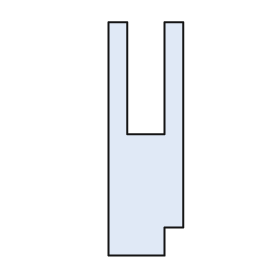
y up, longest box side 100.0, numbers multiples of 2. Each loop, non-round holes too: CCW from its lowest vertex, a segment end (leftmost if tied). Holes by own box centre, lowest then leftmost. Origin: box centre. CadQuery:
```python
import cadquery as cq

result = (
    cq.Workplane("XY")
    .moveTo(-16.0, -50.0)
    .lineTo(8.0, -50.0)
    .lineTo(8.0, -38.0)
    .lineTo(16.0, -38.0)
    .lineTo(16.0, 50.0)
    .lineTo(8.0, 50.0)
    .lineTo(8.0, 2.0)
    .lineTo(-8.0, 2.0)
    .lineTo(-8.0, 50.0)
    .lineTo(-16.0, 50.0)
    .close()
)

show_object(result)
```